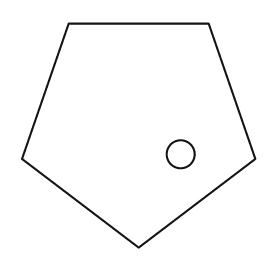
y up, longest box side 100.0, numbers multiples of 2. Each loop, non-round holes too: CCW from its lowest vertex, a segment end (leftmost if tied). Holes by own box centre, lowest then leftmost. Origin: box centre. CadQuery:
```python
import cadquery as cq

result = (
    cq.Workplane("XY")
    .moveTo(0.0, -48.0)
    .lineTo(50.0, -10.0)
    .lineTo(30.0, 48.0)
    .lineTo(-30.0, 48.0)
    .lineTo(-50.0, -10.0)
    .close()
    .moveTo(18.0, -8.0)
    .circle(6.0)
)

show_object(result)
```